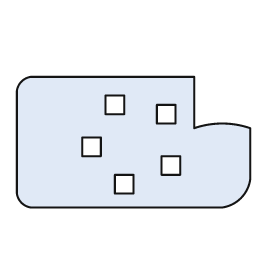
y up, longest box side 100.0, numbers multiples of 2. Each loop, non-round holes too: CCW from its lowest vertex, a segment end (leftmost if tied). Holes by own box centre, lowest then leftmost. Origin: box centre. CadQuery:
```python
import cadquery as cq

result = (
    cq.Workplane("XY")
    .moveTo(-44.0, -28.0)
    .lineTo(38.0, -28.0)
    .threePointArc((46.0, -24.0), (50.0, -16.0))
    .lineTo(50.0, 6.0)
    .threePointArc((38.0, 8.0), (26.0, 6.0))
    .lineTo(26.0, 28.0)
    .lineTo(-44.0, 28.0)
    .threePointArc((-48.0, 26.0), (-50.0, 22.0))
    .lineTo(-50.0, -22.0)
    .threePointArc((-48.0, -26.0), (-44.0, -28.0))
    .close()
    .moveTo(-8.0, -22.0)
    .lineTo(0.0, -22.0)
    .lineTo(0.0, -14.0)
    .lineTo(-8.0, -14.0)
    .close()
    .moveTo(12.0, -14.0)
    .lineTo(20.0, -14.0)
    .lineTo(20.0, -6.0)
    .lineTo(12.0, -6.0)
    .close()
    .moveTo(-22.0, -6.0)
    .lineTo(-14.0, -6.0)
    .lineTo(-14.0, 2.0)
    .lineTo(-22.0, 2.0)
    .close()
    .moveTo(10.0, 8.0)
    .lineTo(18.0, 8.0)
    .lineTo(18.0, 16.0)
    .lineTo(10.0, 16.0)
    .close()
    .moveTo(-12.0, 12.0)
    .lineTo(-4.0, 12.0)
    .lineTo(-4.0, 20.0)
    .lineTo(-12.0, 20.0)
    .close()
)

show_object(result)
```